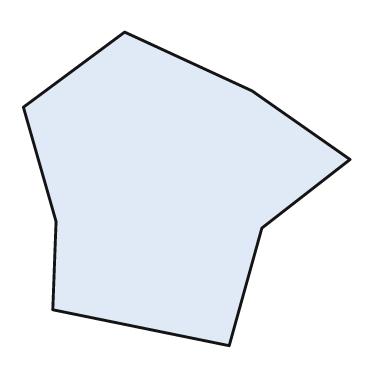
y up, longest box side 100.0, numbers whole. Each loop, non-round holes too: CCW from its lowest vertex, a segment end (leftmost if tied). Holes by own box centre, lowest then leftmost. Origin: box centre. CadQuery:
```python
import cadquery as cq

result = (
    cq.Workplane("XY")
    .moveTo(13.0, -48.0)
    .lineTo(23.0, -12.0)
    .lineTo(50.0, 9.0)
    .lineTo(20.0, 30.0)
    .lineTo(-19.0, 48.0)
    .lineTo(-50.0, 25.0)
    .lineTo(-40.0, -10.0)
    .lineTo(-41.0, -37.0)
    .close()
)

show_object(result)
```